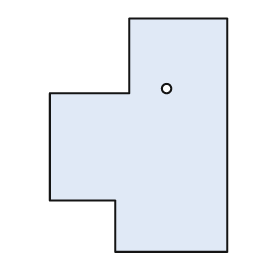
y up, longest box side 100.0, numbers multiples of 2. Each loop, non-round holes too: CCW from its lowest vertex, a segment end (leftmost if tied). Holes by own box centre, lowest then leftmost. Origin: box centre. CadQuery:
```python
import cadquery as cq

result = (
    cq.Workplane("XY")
    .moveTo(-10.0, -50.0)
    .lineTo(38.0, -50.0)
    .lineTo(38.0, 50.0)
    .lineTo(-4.0, 50.0)
    .lineTo(-4.0, 18.0)
    .lineTo(-38.0, 18.0)
    .lineTo(-38.0, -28.0)
    .lineTo(-10.0, -28.0)
    .close()
    .moveTo(12.0, 20.0)
    .circle(2.0)
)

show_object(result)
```